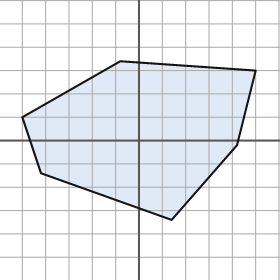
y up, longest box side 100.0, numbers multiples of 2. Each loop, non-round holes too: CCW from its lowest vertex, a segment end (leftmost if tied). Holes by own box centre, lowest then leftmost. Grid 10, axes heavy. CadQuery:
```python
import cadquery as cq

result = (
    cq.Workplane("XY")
    .moveTo(14.0, -34.0)
    .lineTo(42.0, -2.0)
    .lineTo(50.0, 30.0)
    .lineTo(-8.0, 34.0)
    .lineTo(-50.0, 10.0)
    .lineTo(-42.0, -14.0)
    .close()
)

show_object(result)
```